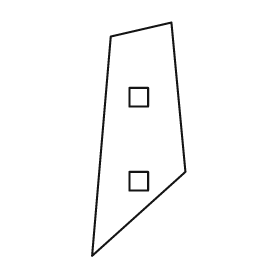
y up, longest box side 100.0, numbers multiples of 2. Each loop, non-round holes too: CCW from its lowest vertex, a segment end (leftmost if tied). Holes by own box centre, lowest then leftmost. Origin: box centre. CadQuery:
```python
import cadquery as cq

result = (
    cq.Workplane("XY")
    .moveTo(-20.0, -50.0)
    .lineTo(20.0, -14.0)
    .lineTo(14.0, 50.0)
    .lineTo(-12.0, 44.0)
    .close()
    .moveTo(-4.0, -22.0)
    .lineTo(4.0, -22.0)
    .lineTo(4.0, -14.0)
    .lineTo(-4.0, -14.0)
    .close()
    .moveTo(-4.0, 14.0)
    .lineTo(4.0, 14.0)
    .lineTo(4.0, 22.0)
    .lineTo(-4.0, 22.0)
    .close()
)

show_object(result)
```